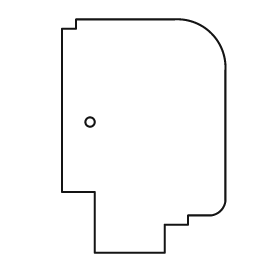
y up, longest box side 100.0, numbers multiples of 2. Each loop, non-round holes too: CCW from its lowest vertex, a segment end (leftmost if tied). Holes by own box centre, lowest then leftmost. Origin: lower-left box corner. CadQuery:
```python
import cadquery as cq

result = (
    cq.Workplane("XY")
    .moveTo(14.0, 0.0)
    .lineTo(44.0, 0.0)
    .lineTo(44.0, 12.0)
    .lineTo(54.0, 12.0)
    .lineTo(54.0, 16.0)
    .lineTo(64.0, 16.0)
    .threePointArc((68.0, 18.0), (70.0, 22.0))
    .lineTo(70.0, 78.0)
    .threePointArc((64.0, 94.0), (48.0, 100.0))
    .lineTo(6.0, 100.0)
    .lineTo(6.0, 96.0)
    .lineTo(0.0, 96.0)
    .lineTo(0.0, 26.0)
    .lineTo(14.0, 26.0)
    .close()
    .moveTo(12.0, 56.0)
    .circle(2.0)
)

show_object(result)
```